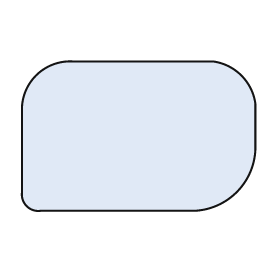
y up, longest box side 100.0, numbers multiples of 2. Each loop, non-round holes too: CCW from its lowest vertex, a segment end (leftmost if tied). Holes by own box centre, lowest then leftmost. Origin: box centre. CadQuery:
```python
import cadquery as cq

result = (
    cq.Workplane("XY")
    .moveTo(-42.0, -32.0)
    .lineTo(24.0, -32.0)
    .threePointArc((42.0, -24.0), (50.0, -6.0))
    .lineTo(50.0, 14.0)
    .threePointArc((44.0, 26.0), (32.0, 32.0))
    .lineTo(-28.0, 32.0)
    .threePointArc((-44.0, 26.0), (-50.0, 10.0))
    .lineTo(-50.0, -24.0)
    .threePointArc((-48.0, -30.0), (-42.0, -32.0))
    .close()
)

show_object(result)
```